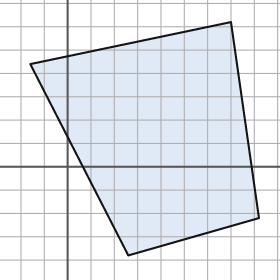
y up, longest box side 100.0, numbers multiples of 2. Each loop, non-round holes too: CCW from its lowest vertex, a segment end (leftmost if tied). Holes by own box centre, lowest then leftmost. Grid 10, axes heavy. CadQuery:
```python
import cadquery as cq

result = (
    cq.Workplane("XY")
    .moveTo(26.0, -38.0)
    .lineTo(82.0, -22.0)
    .lineTo(70.0, 62.0)
    .lineTo(-16.0, 44.0)
    .close()
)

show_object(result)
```